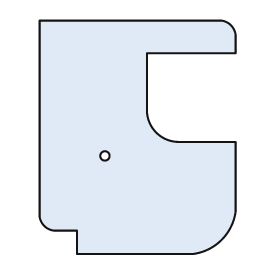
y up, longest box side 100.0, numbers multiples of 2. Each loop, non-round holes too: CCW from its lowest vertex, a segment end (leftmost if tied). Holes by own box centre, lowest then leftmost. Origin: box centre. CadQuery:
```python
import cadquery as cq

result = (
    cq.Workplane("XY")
    .moveTo(-26.0, -50.0)
    .lineTo(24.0, -50.0)
    .threePointArc((36.0, -44.0), (42.0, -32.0))
    .lineTo(42.0, -2.0)
    .lineTo(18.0, -2.0)
    .threePointArc((8.0, 2.0), (4.0, 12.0))
    .lineTo(4.0, 36.0)
    .lineTo(42.0, 36.0)
    .lineTo(42.0, 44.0)
    .threePointArc((40.0, 48.0), (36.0, 50.0))
    .lineTo(-42.0, 50.0)
    .lineTo(-42.0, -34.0)
    .threePointArc((-40.0, -38.0), (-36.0, -40.0))
    .lineTo(-26.0, -40.0)
    .close()
    .moveTo(-14.0, -8.0)
    .circle(2.0)
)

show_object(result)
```